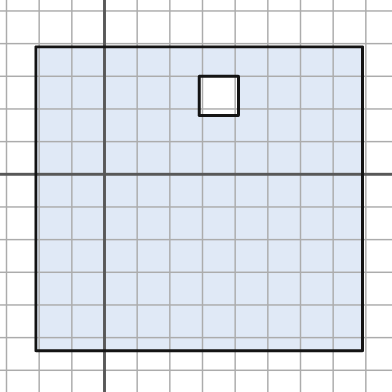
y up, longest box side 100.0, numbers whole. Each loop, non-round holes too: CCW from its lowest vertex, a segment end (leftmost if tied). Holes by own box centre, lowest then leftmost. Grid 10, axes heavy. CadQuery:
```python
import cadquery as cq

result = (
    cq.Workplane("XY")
    .moveTo(-21.0, -54.0)
    .lineTo(79.0, -54.0)
    .lineTo(79.0, 39.0)
    .lineTo(-21.0, 39.0)
    .close()
    .moveTo(29.0, 18.0)
    .lineTo(41.0, 18.0)
    .lineTo(41.0, 30.0)
    .lineTo(29.0, 30.0)
    .close()
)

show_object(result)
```